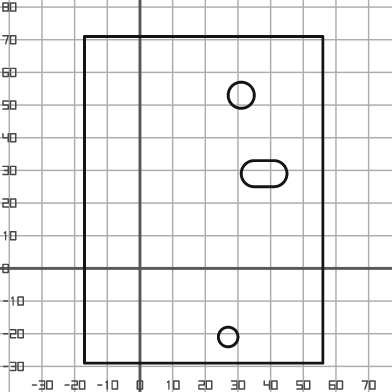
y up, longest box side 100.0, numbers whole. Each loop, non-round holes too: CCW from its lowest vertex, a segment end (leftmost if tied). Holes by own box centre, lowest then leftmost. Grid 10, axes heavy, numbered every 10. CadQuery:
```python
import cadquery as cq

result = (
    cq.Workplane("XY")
    .moveTo(-17.0, -29.0)
    .lineTo(56.0, -29.0)
    .lineTo(56.0, 71.0)
    .lineTo(-17.0, 71.0)
    .close()
    .moveTo(27.0, -21.0)
    .circle(3.0)
    .moveTo(35.0, 25.0)
    .lineTo(41.0, 25.0)
    .threePointArc((45.0, 29.0), (41.0, 33.0))
    .lineTo(35.0, 33.0)
    .threePointArc((31.0, 29.0), (35.0, 25.0))
    .close()
    .moveTo(31.0, 53.0)
    .circle(4.0)
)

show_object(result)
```